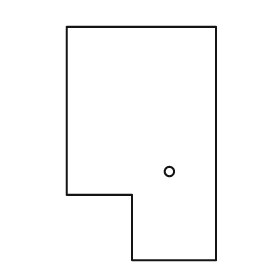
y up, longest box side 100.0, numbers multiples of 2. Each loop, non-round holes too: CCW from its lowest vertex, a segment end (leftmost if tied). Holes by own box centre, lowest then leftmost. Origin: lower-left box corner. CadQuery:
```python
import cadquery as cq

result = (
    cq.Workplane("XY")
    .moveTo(28.0, 0.0)
    .lineTo(64.0, 0.0)
    .lineTo(64.0, 100.0)
    .lineTo(0.0, 100.0)
    .lineTo(0.0, 28.0)
    .lineTo(28.0, 28.0)
    .close()
    .moveTo(44.0, 38.0)
    .circle(2.0)
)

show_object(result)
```